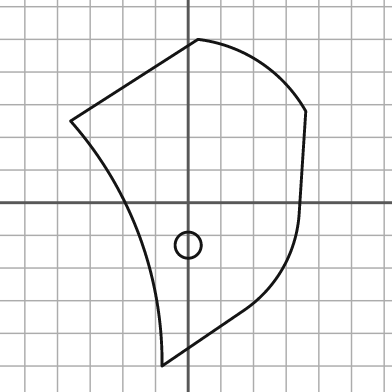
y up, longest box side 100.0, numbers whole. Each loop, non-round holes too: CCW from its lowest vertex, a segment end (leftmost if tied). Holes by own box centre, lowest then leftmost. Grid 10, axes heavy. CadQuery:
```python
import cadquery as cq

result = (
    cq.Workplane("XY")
    .moveTo(-8.0, -50.0)
    .lineTo(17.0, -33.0)
    .threePointArc((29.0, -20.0), (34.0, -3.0))
    .lineTo(36.0, 28.0)
    .threePointArc((22.0, 43.0), (3.0, 50.0))
    .lineTo(-36.0, 25.0)
    .threePointArc((-15.0, -10.0), (-8.0, -50.0))
    .close()
    .moveTo(0.0, -13.0)
    .circle(4.0)
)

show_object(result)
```